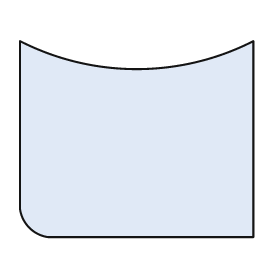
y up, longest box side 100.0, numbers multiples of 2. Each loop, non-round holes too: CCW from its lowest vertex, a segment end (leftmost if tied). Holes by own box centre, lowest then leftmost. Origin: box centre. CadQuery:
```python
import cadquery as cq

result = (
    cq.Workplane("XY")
    .moveTo(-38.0, -42.0)
    .lineTo(50.0, -42.0)
    .lineTo(50.0, 42.0)
    .threePointArc((0.0, 30.0), (-50.0, 42.0))
    .lineTo(-50.0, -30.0)
    .threePointArc((-46.0, -38.0), (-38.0, -42.0))
    .close()
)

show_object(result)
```